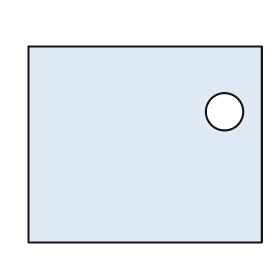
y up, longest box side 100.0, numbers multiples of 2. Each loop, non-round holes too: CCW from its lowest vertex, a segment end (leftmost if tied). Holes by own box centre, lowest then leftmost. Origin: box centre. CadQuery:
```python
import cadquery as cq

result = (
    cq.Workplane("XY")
    .moveTo(-50.0, -42.0)
    .lineTo(50.0, -42.0)
    .lineTo(50.0, 42.0)
    .lineTo(-50.0, 42.0)
    .close()
    .moveTo(34.0, 14.0)
    .circle(8.0)
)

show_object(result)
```